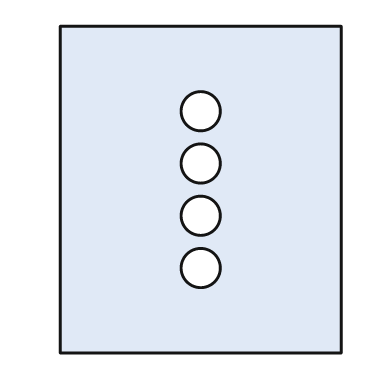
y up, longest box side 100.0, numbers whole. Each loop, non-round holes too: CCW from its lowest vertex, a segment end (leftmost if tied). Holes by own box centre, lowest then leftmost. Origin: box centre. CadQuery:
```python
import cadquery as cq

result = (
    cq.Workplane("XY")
    .moveTo(-43.0, -50.0)
    .lineTo(43.0, -50.0)
    .lineTo(43.0, 50.0)
    .lineTo(-43.0, 50.0)
    .close()
    .moveTo(0.0, -24.0)
    .circle(6.0)
    .moveTo(0.0, -8.0)
    .circle(6.0)
    .moveTo(0.0, 8.0)
    .circle(6.0)
    .moveTo(0.0, 24.0)
    .circle(6.0)
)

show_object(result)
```